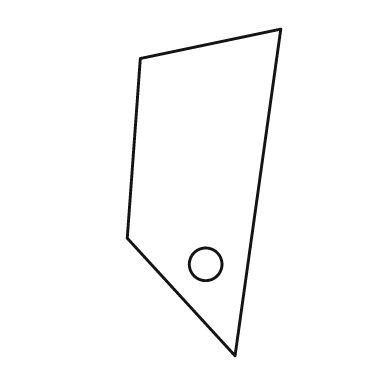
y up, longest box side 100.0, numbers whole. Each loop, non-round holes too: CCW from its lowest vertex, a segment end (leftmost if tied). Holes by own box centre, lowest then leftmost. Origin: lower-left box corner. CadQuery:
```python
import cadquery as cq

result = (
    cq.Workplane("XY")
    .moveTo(33.0, 0.0)
    .lineTo(47.0, 100.0)
    .lineTo(4.0, 91.0)
    .lineTo(0.0, 36.0)
    .close()
    .moveTo(24.0, 28.0)
    .circle(5.0)
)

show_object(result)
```